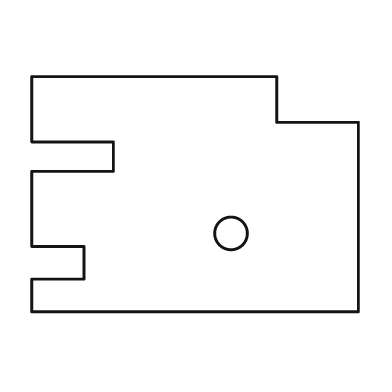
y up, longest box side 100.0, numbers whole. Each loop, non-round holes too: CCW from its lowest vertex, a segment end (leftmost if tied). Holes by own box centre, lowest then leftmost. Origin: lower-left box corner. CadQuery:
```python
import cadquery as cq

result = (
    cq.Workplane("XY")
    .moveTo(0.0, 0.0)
    .lineTo(100.0, 0.0)
    .lineTo(100.0, 58.0)
    .lineTo(75.0, 58.0)
    .lineTo(75.0, 72.0)
    .lineTo(0.0, 72.0)
    .lineTo(0.0, 52.0)
    .lineTo(25.0, 52.0)
    .lineTo(25.0, 43.0)
    .lineTo(0.0, 43.0)
    .lineTo(0.0, 20.0)
    .lineTo(16.0, 20.0)
    .lineTo(16.0, 10.0)
    .lineTo(0.0, 10.0)
    .close()
    .moveTo(61.0, 24.0)
    .circle(5.0)
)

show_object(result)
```